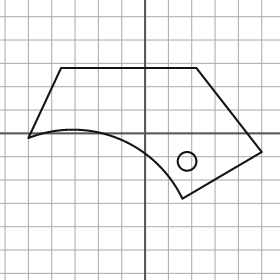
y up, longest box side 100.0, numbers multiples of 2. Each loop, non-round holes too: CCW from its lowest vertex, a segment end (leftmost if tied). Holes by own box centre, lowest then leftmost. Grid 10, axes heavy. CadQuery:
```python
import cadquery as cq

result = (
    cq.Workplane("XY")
    .moveTo(16.0, -28.0)
    .lineTo(50.0, -8.0)
    .lineTo(22.0, 28.0)
    .lineTo(-36.0, 28.0)
    .lineTo(-50.0, -2.0)
    .threePointArc((-12.0, -2.0), (16.0, -28.0))
    .close()
    .moveTo(18.0, -12.0)
    .circle(4.0)
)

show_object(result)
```